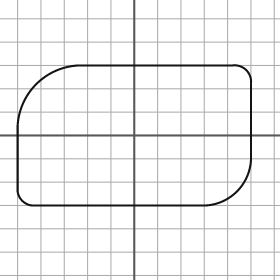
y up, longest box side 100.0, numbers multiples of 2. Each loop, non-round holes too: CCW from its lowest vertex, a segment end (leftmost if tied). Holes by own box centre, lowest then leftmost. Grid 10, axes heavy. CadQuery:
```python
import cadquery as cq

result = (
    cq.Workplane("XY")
    .moveTo(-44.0, -30.0)
    .lineTo(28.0, -30.0)
    .threePointArc((44.0, -24.0), (50.0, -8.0))
    .lineTo(50.0, 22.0)
    .threePointArc((48.0, 28.0), (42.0, 30.0))
    .lineTo(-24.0, 30.0)
    .threePointArc((-42.0, 22.0), (-50.0, 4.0))
    .lineTo(-50.0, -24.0)
    .threePointArc((-48.0, -28.0), (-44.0, -30.0))
    .close()
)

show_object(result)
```